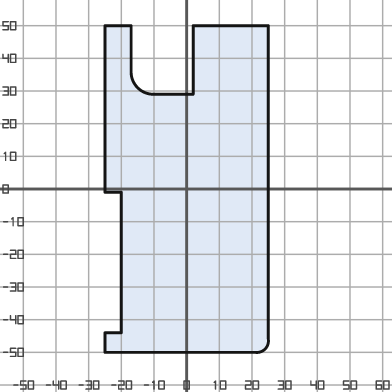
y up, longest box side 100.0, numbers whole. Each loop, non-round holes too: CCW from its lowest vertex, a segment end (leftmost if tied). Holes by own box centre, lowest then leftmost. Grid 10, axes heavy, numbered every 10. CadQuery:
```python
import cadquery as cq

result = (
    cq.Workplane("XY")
    .moveTo(-25.0, -50.0)
    .lineTo(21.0, -50.0)
    .threePointArc((24.0, -49.0), (25.0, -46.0))
    .lineTo(25.0, 50.0)
    .lineTo(2.0, 50.0)
    .lineTo(2.0, 29.0)
    .lineTo(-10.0, 29.0)
    .threePointArc((-15.0, 31.0), (-17.0, 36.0))
    .lineTo(-17.0, 50.0)
    .lineTo(-25.0, 50.0)
    .lineTo(-25.0, -1.0)
    .lineTo(-20.0, -1.0)
    .lineTo(-20.0, -44.0)
    .lineTo(-25.0, -44.0)
    .close()
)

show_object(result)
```